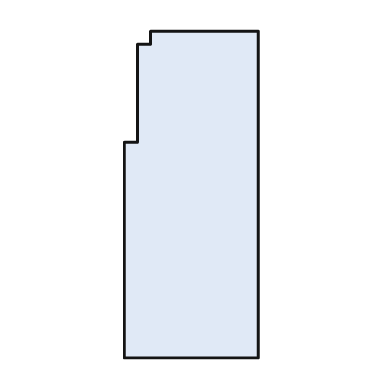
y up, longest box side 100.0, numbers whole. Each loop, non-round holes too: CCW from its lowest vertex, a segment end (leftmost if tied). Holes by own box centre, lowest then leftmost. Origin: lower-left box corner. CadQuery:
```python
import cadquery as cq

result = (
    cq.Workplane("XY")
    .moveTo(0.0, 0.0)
    .lineTo(41.0, 0.0)
    .lineTo(41.0, 100.0)
    .lineTo(8.0, 100.0)
    .lineTo(8.0, 96.0)
    .lineTo(4.0, 96.0)
    .lineTo(4.0, 66.0)
    .lineTo(0.0, 66.0)
    .close()
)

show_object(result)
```